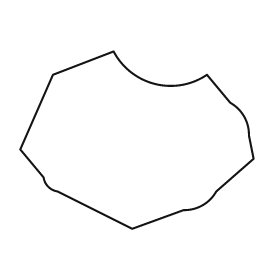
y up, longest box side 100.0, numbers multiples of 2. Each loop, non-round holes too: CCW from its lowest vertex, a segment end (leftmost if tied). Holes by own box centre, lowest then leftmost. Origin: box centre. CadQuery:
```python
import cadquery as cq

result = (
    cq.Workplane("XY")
    .moveTo(-2.0, -38.0)
    .lineTo(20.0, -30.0)
    .threePointArc((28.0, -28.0), (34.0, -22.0))
    .lineTo(50.0, -8.0)
    .lineTo(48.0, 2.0)
    .threePointArc((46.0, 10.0), (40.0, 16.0))
    .lineTo(30.0, 28.0)
    .threePointArc((8.0, 24.0), (-10.0, 38.0))
    .lineTo(-36.0, 28.0)
    .lineTo(-50.0, -4.0)
    .lineTo(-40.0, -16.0)
    .threePointArc((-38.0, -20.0), (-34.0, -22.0))
    .close()
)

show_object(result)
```